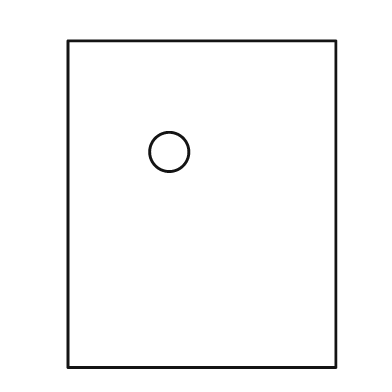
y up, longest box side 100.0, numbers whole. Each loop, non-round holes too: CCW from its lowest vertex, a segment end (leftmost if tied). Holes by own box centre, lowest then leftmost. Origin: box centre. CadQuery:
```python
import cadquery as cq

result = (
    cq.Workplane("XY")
    .moveTo(-41.0, -50.0)
    .lineTo(41.0, -50.0)
    .lineTo(41.0, 50.0)
    .lineTo(-41.0, 50.0)
    .close()
    .moveTo(-10.0, 16.0)
    .circle(6.0)
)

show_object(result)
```